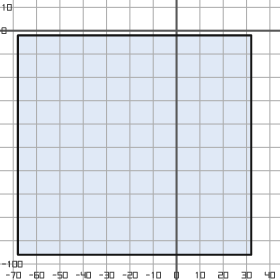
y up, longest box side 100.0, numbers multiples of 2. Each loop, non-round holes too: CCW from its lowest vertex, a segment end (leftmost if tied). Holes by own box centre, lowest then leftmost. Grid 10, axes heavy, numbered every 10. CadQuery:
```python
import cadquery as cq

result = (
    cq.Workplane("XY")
    .moveTo(-68.0, -96.0)
    .lineTo(32.0, -96.0)
    .lineTo(32.0, -2.0)
    .lineTo(-68.0, -2.0)
    .close()
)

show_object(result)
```